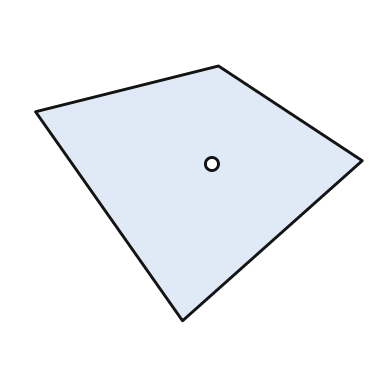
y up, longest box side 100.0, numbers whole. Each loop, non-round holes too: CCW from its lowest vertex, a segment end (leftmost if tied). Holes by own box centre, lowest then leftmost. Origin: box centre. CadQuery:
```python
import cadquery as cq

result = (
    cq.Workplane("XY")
    .moveTo(-5.0, -39.0)
    .lineTo(50.0, 10.0)
    .lineTo(6.0, 39.0)
    .lineTo(-50.0, 25.0)
    .close()
    .moveTo(4.0, 9.0)
    .circle(2.0)
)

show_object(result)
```